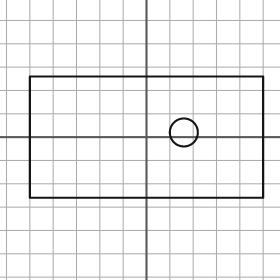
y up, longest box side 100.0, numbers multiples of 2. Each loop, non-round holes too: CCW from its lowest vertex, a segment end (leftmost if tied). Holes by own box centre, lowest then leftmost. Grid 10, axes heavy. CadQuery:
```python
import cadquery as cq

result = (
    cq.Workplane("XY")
    .moveTo(-50.0, -26.0)
    .lineTo(50.0, -26.0)
    .lineTo(50.0, 26.0)
    .lineTo(-50.0, 26.0)
    .close()
    .moveTo(16.0, 2.0)
    .circle(6.0)
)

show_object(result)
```